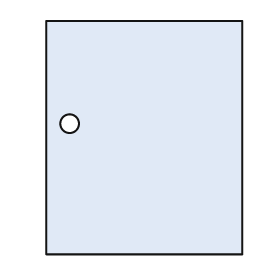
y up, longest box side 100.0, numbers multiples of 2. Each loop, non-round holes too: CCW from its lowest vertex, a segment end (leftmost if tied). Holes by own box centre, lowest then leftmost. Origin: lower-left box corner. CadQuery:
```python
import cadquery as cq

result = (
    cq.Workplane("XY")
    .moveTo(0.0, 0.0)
    .lineTo(84.0, 0.0)
    .lineTo(84.0, 100.0)
    .lineTo(0.0, 100.0)
    .close()
    .moveTo(10.0, 56.0)
    .circle(4.0)
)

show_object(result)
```